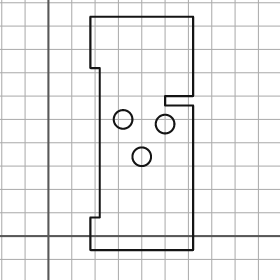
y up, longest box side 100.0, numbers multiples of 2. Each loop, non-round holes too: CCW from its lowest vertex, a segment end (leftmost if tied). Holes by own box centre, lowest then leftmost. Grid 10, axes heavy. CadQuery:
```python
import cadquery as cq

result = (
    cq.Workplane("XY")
    .moveTo(18.0, -6.0)
    .lineTo(62.0, -6.0)
    .lineTo(62.0, 56.0)
    .lineTo(50.0, 56.0)
    .lineTo(50.0, 60.0)
    .lineTo(62.0, 60.0)
    .lineTo(62.0, 94.0)
    .lineTo(18.0, 94.0)
    .lineTo(18.0, 72.0)
    .lineTo(22.0, 72.0)
    .lineTo(22.0, 8.0)
    .lineTo(18.0, 8.0)
    .close()
    .moveTo(40.0, 34.0)
    .circle(4.0)
    .moveTo(50.0, 48.0)
    .circle(4.0)
    .moveTo(32.0, 50.0)
    .circle(4.0)
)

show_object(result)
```